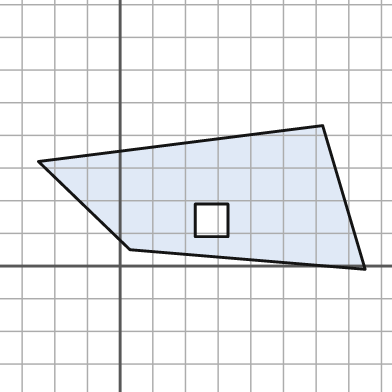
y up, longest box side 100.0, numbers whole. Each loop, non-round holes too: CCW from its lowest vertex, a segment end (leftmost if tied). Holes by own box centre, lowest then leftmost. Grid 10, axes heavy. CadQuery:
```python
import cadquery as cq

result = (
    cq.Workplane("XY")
    .moveTo(75.0, -1.0)
    .lineTo(62.0, 43.0)
    .lineTo(-25.0, 32.0)
    .lineTo(3.0, 5.0)
    .close()
    .moveTo(23.0, 9.0)
    .lineTo(33.0, 9.0)
    .lineTo(33.0, 19.0)
    .lineTo(23.0, 19.0)
    .close()
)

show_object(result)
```